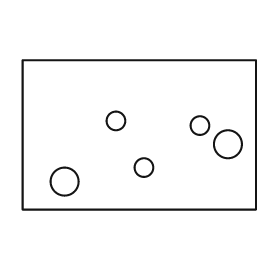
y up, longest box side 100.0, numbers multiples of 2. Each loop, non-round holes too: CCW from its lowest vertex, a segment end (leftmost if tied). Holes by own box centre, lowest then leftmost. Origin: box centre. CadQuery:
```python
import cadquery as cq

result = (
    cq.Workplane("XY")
    .moveTo(-50.0, -32.0)
    .lineTo(50.0, -32.0)
    .lineTo(50.0, 32.0)
    .lineTo(-50.0, 32.0)
    .close()
    .moveTo(-32.0, -20.0)
    .circle(6.0)
    .moveTo(2.0, -14.0)
    .circle(4.0)
    .moveTo(38.0, -4.0)
    .circle(6.0)
    .moveTo(26.0, 4.0)
    .circle(4.0)
    .moveTo(-10.0, 6.0)
    .circle(4.0)
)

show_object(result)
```